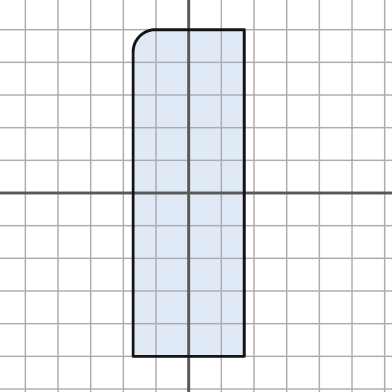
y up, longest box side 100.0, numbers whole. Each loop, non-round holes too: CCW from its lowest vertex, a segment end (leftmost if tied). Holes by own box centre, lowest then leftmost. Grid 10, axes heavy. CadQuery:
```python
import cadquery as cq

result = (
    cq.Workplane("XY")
    .moveTo(-17.0, -50.0)
    .lineTo(17.0, -50.0)
    .lineTo(17.0, 50.0)
    .lineTo(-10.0, 50.0)
    .threePointArc((-15.0, 48.0), (-17.0, 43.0))
    .close()
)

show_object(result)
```